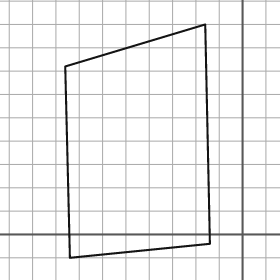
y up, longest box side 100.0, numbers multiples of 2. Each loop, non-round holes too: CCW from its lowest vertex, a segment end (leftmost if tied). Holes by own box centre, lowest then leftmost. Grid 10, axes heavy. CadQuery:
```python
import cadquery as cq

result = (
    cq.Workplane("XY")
    .moveTo(-74.0, -10.0)
    .lineTo(-14.0, -4.0)
    .lineTo(-16.0, 90.0)
    .lineTo(-76.0, 72.0)
    .close()
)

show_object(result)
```